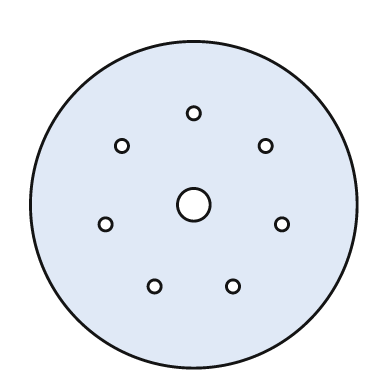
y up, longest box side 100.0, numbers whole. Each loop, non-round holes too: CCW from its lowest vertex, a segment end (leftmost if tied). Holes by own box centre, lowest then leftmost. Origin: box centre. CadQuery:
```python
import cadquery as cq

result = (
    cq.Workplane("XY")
    .moveTo(0.0, 0.0)
    .circle(50.0)
    .moveTo(-12.0, -25.0)
    .circle(2.0)
    .moveTo(12.0, -25.0)
    .circle(2.0)
    .moveTo(-27.0, -6.0)
    .circle(2.0)
    .moveTo(27.0, -6.0)
    .circle(2.0)
    .moveTo(0.0, 0.0)
    .circle(5.0)
    .moveTo(-22.0, 18.0)
    .circle(2.0)
    .moveTo(22.0, 18.0)
    .circle(2.0)
    .moveTo(0.0, 28.0)
    .circle(2.0)
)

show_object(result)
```